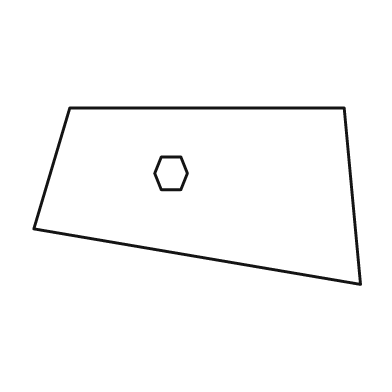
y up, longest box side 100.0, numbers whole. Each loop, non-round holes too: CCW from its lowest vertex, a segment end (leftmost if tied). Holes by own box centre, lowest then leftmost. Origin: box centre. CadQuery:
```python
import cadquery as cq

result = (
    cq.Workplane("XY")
    .moveTo(50.0, -27.0)
    .lineTo(45.0, 27.0)
    .lineTo(-39.0, 27.0)
    .lineTo(-50.0, -10.0)
    .close()
    .moveTo(-11.0, 2.0)
    .lineTo(-5.0, 2.0)
    .lineTo(-3.0, 7.0)
    .lineTo(-5.0, 12.0)
    .lineTo(-11.0, 12.0)
    .lineTo(-13.0, 7.0)
    .close()
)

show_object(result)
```